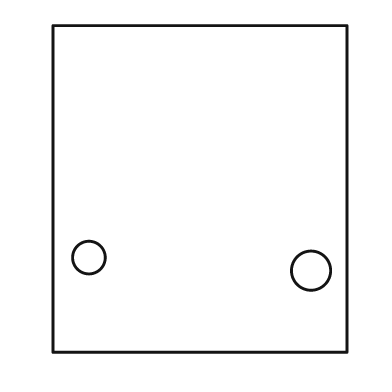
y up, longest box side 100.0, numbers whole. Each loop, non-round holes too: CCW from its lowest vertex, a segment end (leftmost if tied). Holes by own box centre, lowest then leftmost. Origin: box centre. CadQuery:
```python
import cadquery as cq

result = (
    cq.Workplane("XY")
    .moveTo(-45.0, -50.0)
    .lineTo(45.0, -50.0)
    .lineTo(45.0, 50.0)
    .lineTo(-45.0, 50.0)
    .close()
    .moveTo(34.0, -25.0)
    .circle(6.0)
    .moveTo(-34.0, -21.0)
    .circle(5.0)
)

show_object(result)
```